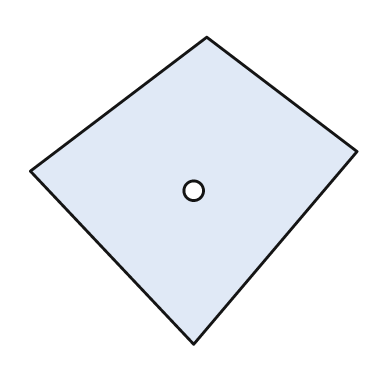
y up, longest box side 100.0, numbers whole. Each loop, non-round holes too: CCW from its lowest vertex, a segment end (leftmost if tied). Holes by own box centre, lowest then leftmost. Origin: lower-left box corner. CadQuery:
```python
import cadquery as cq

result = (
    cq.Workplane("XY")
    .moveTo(50.0, 0.0)
    .lineTo(100.0, 59.0)
    .lineTo(54.0, 94.0)
    .lineTo(0.0, 53.0)
    .close()
    .moveTo(50.0, 47.0)
    .circle(3.0)
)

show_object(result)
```